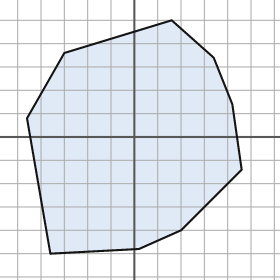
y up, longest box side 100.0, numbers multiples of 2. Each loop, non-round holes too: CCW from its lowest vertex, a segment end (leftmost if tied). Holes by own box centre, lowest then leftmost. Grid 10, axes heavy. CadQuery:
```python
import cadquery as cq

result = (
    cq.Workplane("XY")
    .moveTo(-36.0, -50.0)
    .lineTo(2.0, -48.0)
    .lineTo(20.0, -40.0)
    .lineTo(46.0, -14.0)
    .lineTo(42.0, 14.0)
    .lineTo(34.0, 34.0)
    .lineTo(16.0, 50.0)
    .lineTo(-30.0, 36.0)
    .lineTo(-46.0, 8.0)
    .close()
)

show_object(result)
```